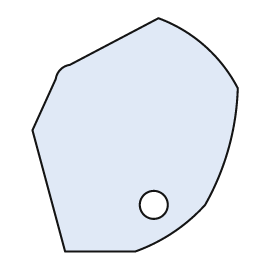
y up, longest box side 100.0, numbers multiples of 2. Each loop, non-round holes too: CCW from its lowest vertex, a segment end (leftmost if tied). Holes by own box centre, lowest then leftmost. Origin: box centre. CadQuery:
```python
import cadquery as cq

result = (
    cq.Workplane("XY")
    .moveTo(-30.0, -50.0)
    .lineTo(0.0, -50.0)
    .threePointArc((16.0, -42.0), (30.0, -30.0))
    .threePointArc((40.0, -6.0), (44.0, 20.0))
    .threePointArc((30.0, 38.0), (10.0, 50.0))
    .lineTo(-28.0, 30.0)
    .threePointArc((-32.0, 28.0), (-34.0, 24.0))
    .lineTo(-44.0, 2.0)
    .close()
    .moveTo(8.0, -30.0)
    .circle(6.0)
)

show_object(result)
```